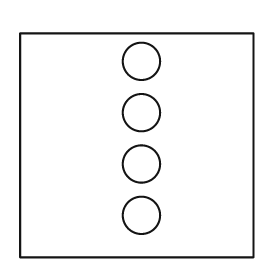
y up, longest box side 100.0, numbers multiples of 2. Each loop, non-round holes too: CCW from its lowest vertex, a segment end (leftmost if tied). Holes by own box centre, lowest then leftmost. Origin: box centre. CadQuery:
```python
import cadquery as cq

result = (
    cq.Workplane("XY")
    .moveTo(-50.0, -48.0)
    .lineTo(50.0, -48.0)
    .lineTo(50.0, 48.0)
    .lineTo(-50.0, 48.0)
    .close()
    .moveTo(2.0, -30.0)
    .circle(8.0)
    .moveTo(2.0, -8.0)
    .circle(8.0)
    .moveTo(2.0, 14.0)
    .circle(8.0)
    .moveTo(2.0, 36.0)
    .circle(8.0)
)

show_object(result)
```